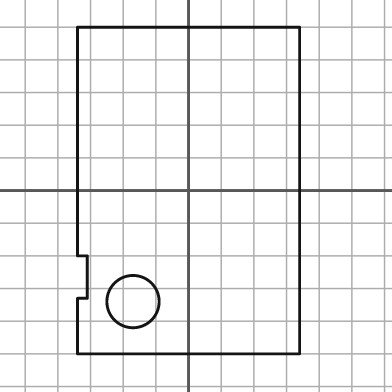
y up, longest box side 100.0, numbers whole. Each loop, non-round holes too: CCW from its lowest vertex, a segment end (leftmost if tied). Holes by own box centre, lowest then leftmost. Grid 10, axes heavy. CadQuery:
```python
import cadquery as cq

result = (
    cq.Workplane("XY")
    .moveTo(-34.0, -50.0)
    .lineTo(34.0, -50.0)
    .lineTo(34.0, 50.0)
    .lineTo(-34.0, 50.0)
    .lineTo(-34.0, -20.0)
    .lineTo(-31.0, -20.0)
    .lineTo(-31.0, -33.0)
    .lineTo(-34.0, -33.0)
    .close()
    .moveTo(-17.0, -34.0)
    .circle(8.0)
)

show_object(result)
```